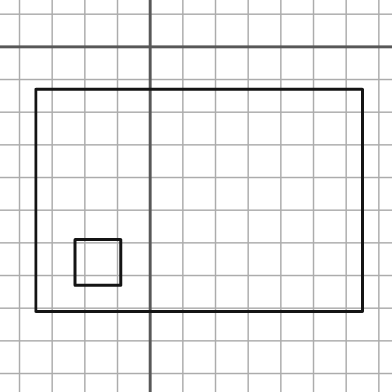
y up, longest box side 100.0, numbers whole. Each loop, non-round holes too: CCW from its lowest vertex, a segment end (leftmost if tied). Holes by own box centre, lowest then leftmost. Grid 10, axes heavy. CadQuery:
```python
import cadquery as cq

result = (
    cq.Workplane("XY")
    .moveTo(-35.0, -81.0)
    .lineTo(65.0, -81.0)
    .lineTo(65.0, -13.0)
    .lineTo(-35.0, -13.0)
    .close()
    .moveTo(-23.0, -73.0)
    .lineTo(-9.0, -73.0)
    .lineTo(-9.0, -59.0)
    .lineTo(-23.0, -59.0)
    .close()
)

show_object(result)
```